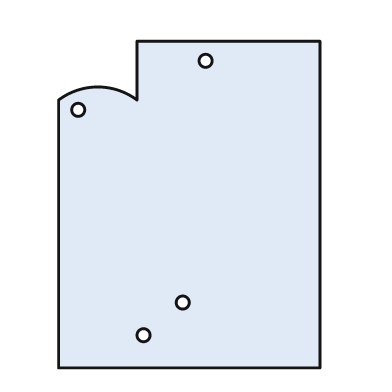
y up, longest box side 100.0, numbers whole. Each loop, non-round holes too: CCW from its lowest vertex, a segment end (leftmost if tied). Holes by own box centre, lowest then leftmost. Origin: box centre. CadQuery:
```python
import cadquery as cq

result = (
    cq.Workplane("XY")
    .moveTo(-40.0, -50.0)
    .lineTo(40.0, -50.0)
    .lineTo(40.0, 50.0)
    .lineTo(-16.0, 50.0)
    .lineTo(-16.0, 32.0)
    .threePointArc((-28.0, 36.0), (-40.0, 32.0))
    .close()
    .moveTo(-14.0, -40.0)
    .circle(2.0)
    .moveTo(-2.0, -30.0)
    .circle(2.0)
    .moveTo(-34.0, 29.0)
    .circle(2.0)
    .moveTo(5.0, 44.0)
    .circle(2.0)
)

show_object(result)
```